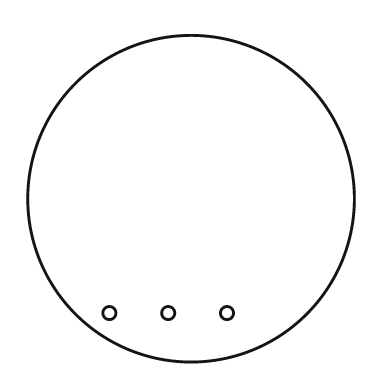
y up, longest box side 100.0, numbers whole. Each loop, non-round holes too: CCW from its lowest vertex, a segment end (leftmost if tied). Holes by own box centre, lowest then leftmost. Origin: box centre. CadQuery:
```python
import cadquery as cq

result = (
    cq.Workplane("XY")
    .moveTo(0.0, 0.0)
    .circle(50.0)
    .moveTo(-25.0, -35.0)
    .circle(2.0)
    .moveTo(-7.0, -35.0)
    .circle(2.0)
    .moveTo(11.0, -35.0)
    .circle(2.0)
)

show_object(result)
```